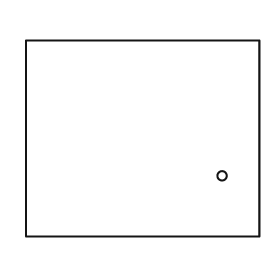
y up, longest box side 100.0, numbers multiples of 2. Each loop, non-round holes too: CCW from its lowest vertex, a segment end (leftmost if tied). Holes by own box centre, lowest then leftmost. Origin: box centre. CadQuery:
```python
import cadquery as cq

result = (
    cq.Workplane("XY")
    .moveTo(-50.0, -42.0)
    .lineTo(50.0, -42.0)
    .lineTo(50.0, 42.0)
    .lineTo(-50.0, 42.0)
    .close()
    .moveTo(34.0, -16.0)
    .circle(2.0)
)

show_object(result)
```